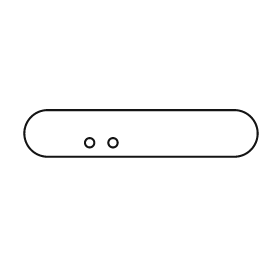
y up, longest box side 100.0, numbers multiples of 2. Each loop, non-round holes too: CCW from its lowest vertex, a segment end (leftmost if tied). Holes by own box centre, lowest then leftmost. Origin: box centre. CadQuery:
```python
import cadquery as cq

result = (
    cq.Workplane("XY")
    .moveTo(-40.0, -10.0)
    .lineTo(40.0, -10.0)
    .threePointArc((50.0, 0.0), (40.0, 10.0))
    .lineTo(-40.0, 10.0)
    .threePointArc((-50.0, 0.0), (-40.0, -10.0))
    .close()
    .moveTo(-22.0, -4.0)
    .circle(2.0)
    .moveTo(-12.0, -4.0)
    .circle(2.0)
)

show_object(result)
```